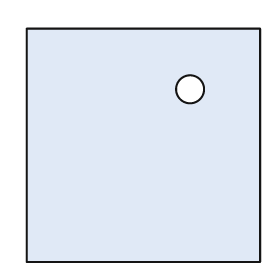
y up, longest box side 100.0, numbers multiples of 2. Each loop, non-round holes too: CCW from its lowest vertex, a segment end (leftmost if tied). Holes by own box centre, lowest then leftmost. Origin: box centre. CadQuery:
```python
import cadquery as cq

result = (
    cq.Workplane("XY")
    .moveTo(-50.0, -50.0)
    .lineTo(50.0, -50.0)
    .lineTo(50.0, 50.0)
    .lineTo(-50.0, 50.0)
    .close()
    .moveTo(20.0, 24.0)
    .circle(6.0)
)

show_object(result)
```